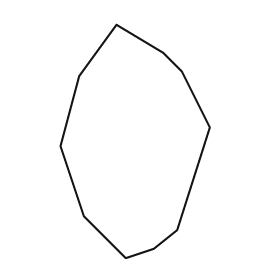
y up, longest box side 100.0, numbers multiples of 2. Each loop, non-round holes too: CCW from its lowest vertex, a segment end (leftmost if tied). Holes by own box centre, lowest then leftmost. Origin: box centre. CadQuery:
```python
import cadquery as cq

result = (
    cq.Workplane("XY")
    .moveTo(-4.0, -50.0)
    .lineTo(8.0, -46.0)
    .lineTo(18.0, -38.0)
    .lineTo(32.0, 6.0)
    .lineTo(20.0, 30.0)
    .lineTo(12.0, 38.0)
    .lineTo(-8.0, 50.0)
    .lineTo(-24.0, 28.0)
    .lineTo(-32.0, -2.0)
    .lineTo(-22.0, -32.0)
    .close()
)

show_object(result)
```